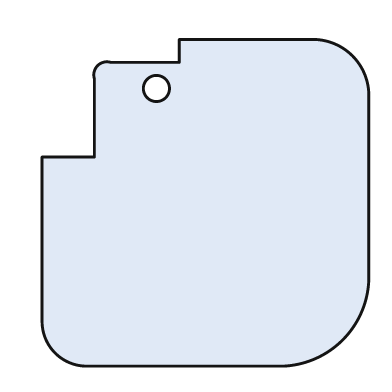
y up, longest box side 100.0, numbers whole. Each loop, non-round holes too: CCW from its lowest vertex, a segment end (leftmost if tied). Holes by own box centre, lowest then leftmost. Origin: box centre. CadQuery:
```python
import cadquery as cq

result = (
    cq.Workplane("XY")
    .moveTo(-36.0, -50.0)
    .lineTo(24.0, -50.0)
    .threePointArc((42.0, -42.0), (50.0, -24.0))
    .lineTo(50.0, 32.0)
    .threePointArc((45.0, 45.0), (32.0, 50.0))
    .lineTo(-8.0, 50.0)
    .lineTo(-8.0, 43.0)
    .lineTo(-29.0, 43.0)
    .threePointArc((-33.0, 42.0), (-34.0, 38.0))
    .lineTo(-34.0, 14.0)
    .lineTo(-50.0, 14.0)
    .lineTo(-50.0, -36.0)
    .threePointArc((-46.0, -46.0), (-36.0, -50.0))
    .close()
    .moveTo(-15.0, 35.0)
    .circle(4.0)
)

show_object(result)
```